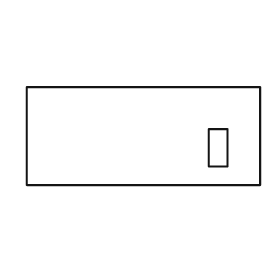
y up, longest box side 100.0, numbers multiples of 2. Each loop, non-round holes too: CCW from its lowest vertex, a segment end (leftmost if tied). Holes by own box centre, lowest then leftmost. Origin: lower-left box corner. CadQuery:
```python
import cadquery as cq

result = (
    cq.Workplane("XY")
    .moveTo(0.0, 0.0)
    .lineTo(100.0, 0.0)
    .lineTo(100.0, 42.0)
    .lineTo(0.0, 42.0)
    .close()
    .moveTo(78.0, 8.0)
    .lineTo(86.0, 8.0)
    .lineTo(86.0, 24.0)
    .lineTo(78.0, 24.0)
    .close()
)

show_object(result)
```